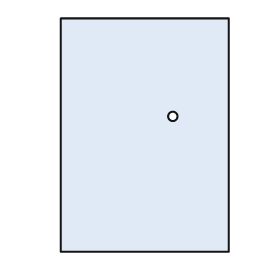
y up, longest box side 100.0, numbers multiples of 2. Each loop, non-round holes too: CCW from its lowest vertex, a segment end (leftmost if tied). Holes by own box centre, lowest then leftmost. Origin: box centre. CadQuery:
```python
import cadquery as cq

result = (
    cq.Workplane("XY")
    .moveTo(-36.0, -50.0)
    .lineTo(36.0, -50.0)
    .lineTo(36.0, 50.0)
    .lineTo(-36.0, 50.0)
    .close()
    .moveTo(12.0, 8.0)
    .circle(2.0)
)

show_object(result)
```